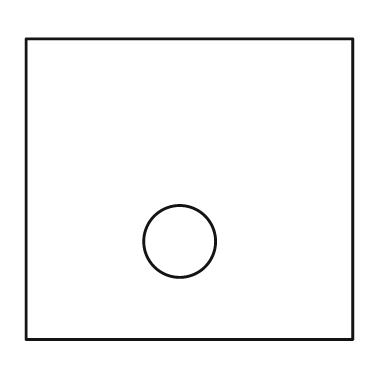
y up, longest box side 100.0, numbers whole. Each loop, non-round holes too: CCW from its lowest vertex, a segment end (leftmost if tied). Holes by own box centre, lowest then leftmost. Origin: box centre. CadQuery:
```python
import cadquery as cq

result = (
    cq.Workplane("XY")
    .moveTo(-50.0, -46.0)
    .lineTo(50.0, -46.0)
    .lineTo(50.0, 46.0)
    .lineTo(-50.0, 46.0)
    .close()
    .moveTo(-3.0, -16.0)
    .circle(11.0)
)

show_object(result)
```